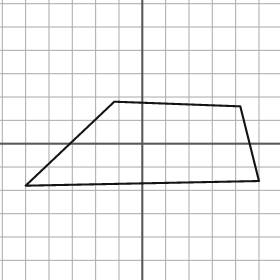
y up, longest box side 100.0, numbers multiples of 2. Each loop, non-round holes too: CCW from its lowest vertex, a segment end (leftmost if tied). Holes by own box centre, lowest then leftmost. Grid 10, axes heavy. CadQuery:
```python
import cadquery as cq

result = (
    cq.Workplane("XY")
    .moveTo(-50.0, -18.0)
    .lineTo(50.0, -16.0)
    .lineTo(42.0, 16.0)
    .lineTo(-12.0, 18.0)
    .close()
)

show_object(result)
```